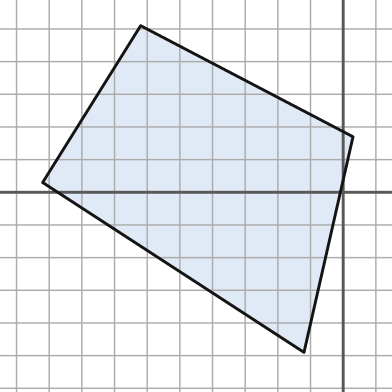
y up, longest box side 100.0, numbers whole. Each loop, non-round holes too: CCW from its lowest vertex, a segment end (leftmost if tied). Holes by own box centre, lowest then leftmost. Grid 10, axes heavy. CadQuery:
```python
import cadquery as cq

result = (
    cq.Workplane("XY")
    .moveTo(-12.0, -49.0)
    .lineTo(3.0, 17.0)
    .lineTo(-62.0, 51.0)
    .lineTo(-92.0, 3.0)
    .close()
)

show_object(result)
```